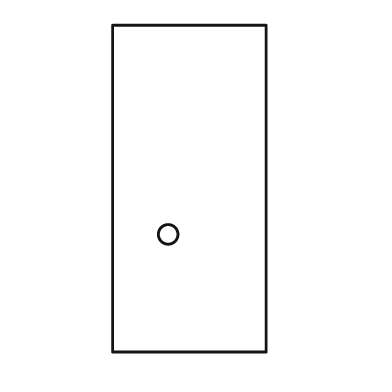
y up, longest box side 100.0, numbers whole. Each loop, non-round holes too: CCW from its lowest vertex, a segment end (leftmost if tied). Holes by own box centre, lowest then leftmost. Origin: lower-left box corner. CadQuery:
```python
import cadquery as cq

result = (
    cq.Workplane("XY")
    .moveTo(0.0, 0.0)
    .lineTo(47.0, 0.0)
    .lineTo(47.0, 100.0)
    .lineTo(0.0, 100.0)
    .close()
    .moveTo(17.0, 36.0)
    .circle(3.0)
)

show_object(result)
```